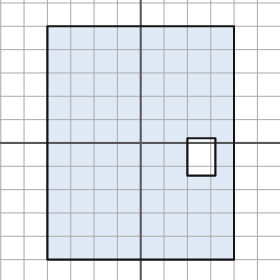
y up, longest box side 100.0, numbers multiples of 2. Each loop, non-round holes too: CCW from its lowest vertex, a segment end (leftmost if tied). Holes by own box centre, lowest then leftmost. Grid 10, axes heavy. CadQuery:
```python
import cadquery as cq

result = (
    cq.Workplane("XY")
    .moveTo(-40.0, -50.0)
    .lineTo(40.0, -50.0)
    .lineTo(40.0, 50.0)
    .lineTo(-40.0, 50.0)
    .close()
    .moveTo(20.0, -14.0)
    .lineTo(32.0, -14.0)
    .lineTo(32.0, 2.0)
    .lineTo(20.0, 2.0)
    .close()
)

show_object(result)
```